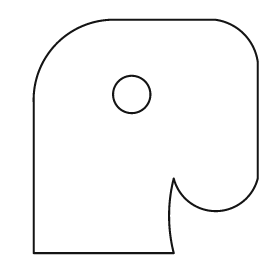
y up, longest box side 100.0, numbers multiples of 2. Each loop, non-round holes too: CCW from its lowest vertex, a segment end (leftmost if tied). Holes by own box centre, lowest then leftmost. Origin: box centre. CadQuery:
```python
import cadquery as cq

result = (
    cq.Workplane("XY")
    .moveTo(-48.0, -50.0)
    .lineTo(12.0, -50.0)
    .threePointArc((10.0, -34.0), (12.0, -18.0))
    .threePointArc((30.0, -32.0), (48.0, -18.0))
    .lineTo(48.0, 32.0)
    .threePointArc((42.0, 44.0), (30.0, 50.0))
    .lineTo(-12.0, 50.0)
    .threePointArc((-38.0, 40.0), (-48.0, 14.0))
    .close()
    .moveTo(-6.0, 18.0)
    .circle(8.0)
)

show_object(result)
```